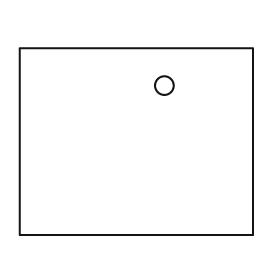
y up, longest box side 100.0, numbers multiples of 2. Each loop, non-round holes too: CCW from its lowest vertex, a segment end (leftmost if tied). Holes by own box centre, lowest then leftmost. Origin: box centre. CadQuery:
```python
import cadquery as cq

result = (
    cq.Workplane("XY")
    .moveTo(-50.0, -40.0)
    .lineTo(50.0, -40.0)
    .lineTo(50.0, 40.0)
    .lineTo(-50.0, 40.0)
    .close()
    .moveTo(12.0, 24.0)
    .circle(4.0)
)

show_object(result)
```